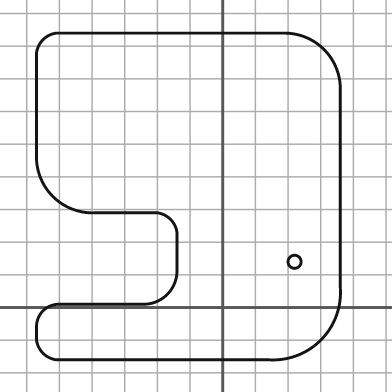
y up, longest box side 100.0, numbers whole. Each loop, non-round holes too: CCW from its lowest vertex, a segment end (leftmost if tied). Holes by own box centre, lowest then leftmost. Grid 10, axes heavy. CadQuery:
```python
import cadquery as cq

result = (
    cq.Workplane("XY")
    .moveTo(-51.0, -16.0)
    .lineTo(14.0, -16.0)
    .threePointArc((30.0, -10.0), (36.0, 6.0))
    .lineTo(36.0, 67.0)
    .threePointArc((31.0, 79.0), (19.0, 84.0))
    .lineTo(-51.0, 84.0)
    .threePointArc((-55.0, 82.0), (-57.0, 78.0))
    .lineTo(-57.0, 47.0)
    .threePointArc((-52.0, 34.0), (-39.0, 29.0))
    .lineTo(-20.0, 29.0)
    .threePointArc((-16.0, 27.0), (-14.0, 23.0))
    .lineTo(-14.0, 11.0)
    .threePointArc((-17.0, 4.0), (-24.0, 1.0))
    .lineTo(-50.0, 1.0)
    .threePointArc((-55.0, -1.0), (-57.0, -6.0))
    .lineTo(-57.0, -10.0)
    .threePointArc((-55.0, -14.0), (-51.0, -16.0))
    .close()
    .moveTo(22.0, 14.0)
    .circle(2.0)
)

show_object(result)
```